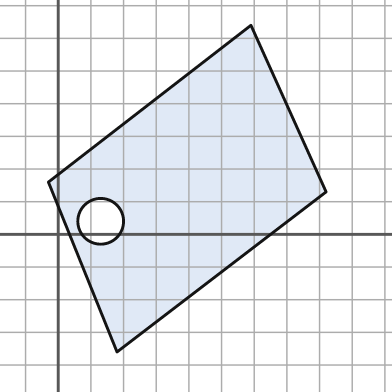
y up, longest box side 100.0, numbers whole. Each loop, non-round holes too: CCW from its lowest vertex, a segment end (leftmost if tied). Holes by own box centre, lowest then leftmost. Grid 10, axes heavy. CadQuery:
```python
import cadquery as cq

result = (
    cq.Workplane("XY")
    .moveTo(18.0, -36.0)
    .lineTo(82.0, 13.0)
    .lineTo(59.0, 64.0)
    .lineTo(-3.0, 16.0)
    .close()
    .moveTo(13.0, 4.0)
    .circle(7.0)
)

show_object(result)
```